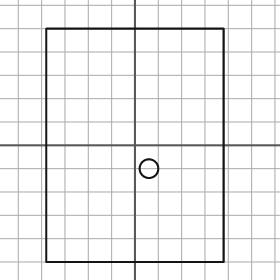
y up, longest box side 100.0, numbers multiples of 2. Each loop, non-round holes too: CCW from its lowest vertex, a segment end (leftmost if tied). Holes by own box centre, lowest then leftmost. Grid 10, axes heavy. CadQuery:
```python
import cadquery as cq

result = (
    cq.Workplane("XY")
    .moveTo(-38.0, -50.0)
    .lineTo(38.0, -50.0)
    .lineTo(38.0, 50.0)
    .lineTo(-38.0, 50.0)
    .close()
    .moveTo(6.0, -10.0)
    .circle(4.0)
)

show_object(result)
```